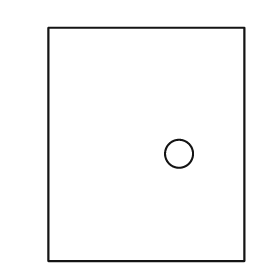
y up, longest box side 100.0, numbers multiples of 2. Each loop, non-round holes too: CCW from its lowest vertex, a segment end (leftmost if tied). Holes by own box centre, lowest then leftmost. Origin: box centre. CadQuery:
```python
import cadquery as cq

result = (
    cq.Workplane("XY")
    .moveTo(-42.0, -50.0)
    .lineTo(42.0, -50.0)
    .lineTo(42.0, 50.0)
    .lineTo(-42.0, 50.0)
    .close()
    .moveTo(14.0, -4.0)
    .circle(6.0)
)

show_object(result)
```